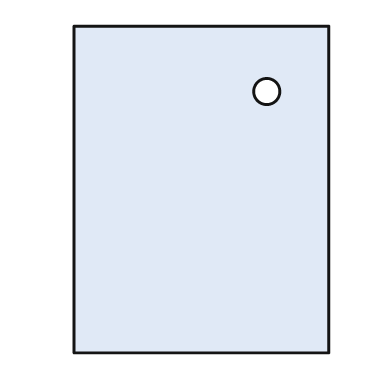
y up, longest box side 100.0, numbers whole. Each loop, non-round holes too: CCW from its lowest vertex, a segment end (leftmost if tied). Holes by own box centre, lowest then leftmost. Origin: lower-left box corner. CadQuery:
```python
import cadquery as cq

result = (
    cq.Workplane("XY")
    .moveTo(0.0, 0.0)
    .lineTo(78.0, 0.0)
    .lineTo(78.0, 100.0)
    .lineTo(0.0, 100.0)
    .close()
    .moveTo(59.0, 80.0)
    .circle(4.0)
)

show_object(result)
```